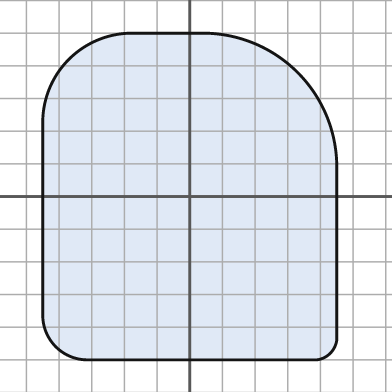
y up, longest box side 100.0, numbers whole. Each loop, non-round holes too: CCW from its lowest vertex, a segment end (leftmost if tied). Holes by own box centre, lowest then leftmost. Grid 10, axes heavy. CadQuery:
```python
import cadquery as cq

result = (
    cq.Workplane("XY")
    .moveTo(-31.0, -50.0)
    .lineTo(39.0, -50.0)
    .threePointArc((43.0, -48.0), (45.0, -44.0))
    .lineTo(45.0, 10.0)
    .threePointArc((33.0, 38.0), (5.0, 50.0))
    .lineTo(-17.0, 50.0)
    .threePointArc((-37.0, 42.0), (-45.0, 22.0))
    .lineTo(-45.0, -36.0)
    .threePointArc((-41.0, -46.0), (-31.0, -50.0))
    .close()
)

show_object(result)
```